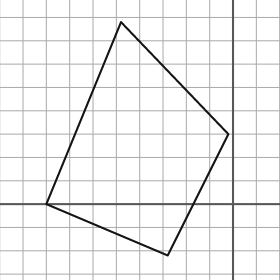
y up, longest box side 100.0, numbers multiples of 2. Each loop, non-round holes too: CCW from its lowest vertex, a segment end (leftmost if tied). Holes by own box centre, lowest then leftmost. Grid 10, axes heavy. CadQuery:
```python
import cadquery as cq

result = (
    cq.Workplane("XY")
    .moveTo(-28.0, -22.0)
    .lineTo(-2.0, 30.0)
    .lineTo(-48.0, 78.0)
    .lineTo(-80.0, 0.0)
    .close()
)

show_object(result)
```